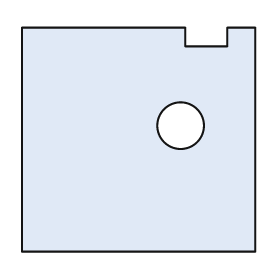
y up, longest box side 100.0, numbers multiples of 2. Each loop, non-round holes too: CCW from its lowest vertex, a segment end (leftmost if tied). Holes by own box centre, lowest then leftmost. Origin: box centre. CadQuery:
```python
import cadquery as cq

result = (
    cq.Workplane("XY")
    .moveTo(-50.0, -48.0)
    .lineTo(50.0, -48.0)
    .lineTo(50.0, 48.0)
    .lineTo(38.0, 48.0)
    .lineTo(38.0, 40.0)
    .lineTo(20.0, 40.0)
    .lineTo(20.0, 48.0)
    .lineTo(-50.0, 48.0)
    .close()
    .moveTo(18.0, 6.0)
    .circle(10.0)
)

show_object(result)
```